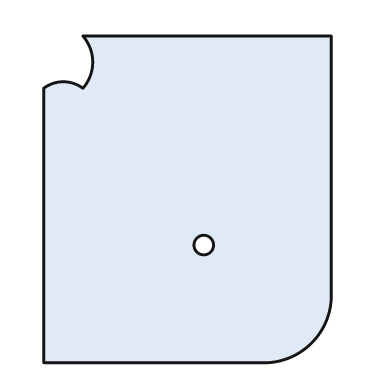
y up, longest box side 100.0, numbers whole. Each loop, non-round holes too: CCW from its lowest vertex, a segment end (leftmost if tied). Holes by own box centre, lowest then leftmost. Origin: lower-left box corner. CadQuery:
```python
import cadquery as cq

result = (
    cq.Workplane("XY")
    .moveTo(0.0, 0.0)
    .lineTo(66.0, 0.0)
    .threePointArc((82.0, 6.0), (88.0, 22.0))
    .lineTo(88.0, 100.0)
    .lineTo(12.0, 100.0)
    .threePointArc((15.0, 92.0), (12.0, 84.0))
    .threePointArc((6.0, 86.0), (0.0, 84.0))
    .close()
    .moveTo(49.0, 36.0)
    .circle(3.0)
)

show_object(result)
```